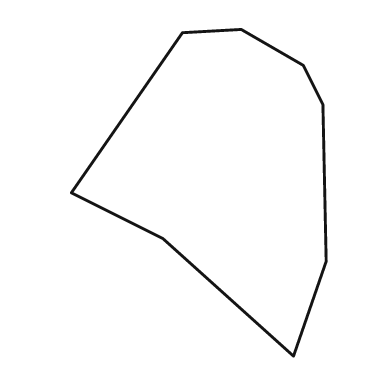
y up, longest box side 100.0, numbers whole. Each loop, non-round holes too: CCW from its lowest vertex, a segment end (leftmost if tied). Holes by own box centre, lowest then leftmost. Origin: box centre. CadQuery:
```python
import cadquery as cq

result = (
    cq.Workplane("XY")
    .moveTo(29.0, -50.0)
    .lineTo(39.0, -21.0)
    .lineTo(38.0, 27.0)
    .lineTo(32.0, 39.0)
    .lineTo(13.0, 50.0)
    .lineTo(-5.0, 49.0)
    .lineTo(-39.0, 0.0)
    .lineTo(-11.0, -14.0)
    .close()
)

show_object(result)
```